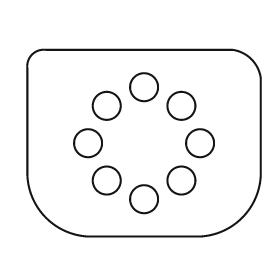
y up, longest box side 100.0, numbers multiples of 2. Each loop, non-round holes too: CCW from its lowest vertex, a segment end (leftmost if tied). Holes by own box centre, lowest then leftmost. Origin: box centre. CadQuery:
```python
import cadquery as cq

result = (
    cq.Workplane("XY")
    .moveTo(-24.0, -40.0)
    .lineTo(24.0, -40.0)
    .threePointArc((42.0, -32.0), (50.0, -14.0))
    .lineTo(50.0, 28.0)
    .threePointArc((46.0, 36.0), (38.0, 40.0))
    .lineTo(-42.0, 40.0)
    .threePointArc((-48.0, 38.0), (-50.0, 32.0))
    .lineTo(-50.0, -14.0)
    .threePointArc((-42.0, -32.0), (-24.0, -40.0))
    .close()
    .moveTo(0.0, -24.0)
    .circle(6.0)
    .moveTo(-16.0, -16.0)
    .circle(6.0)
    .moveTo(16.0, -16.0)
    .circle(6.0)
    .moveTo(-24.0, 0.0)
    .circle(6.0)
    .moveTo(24.0, 0.0)
    .circle(6.0)
    .moveTo(-16.0, 16.0)
    .circle(6.0)
    .moveTo(16.0, 16.0)
    .circle(6.0)
    .moveTo(0.0, 24.0)
    .circle(6.0)
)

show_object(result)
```